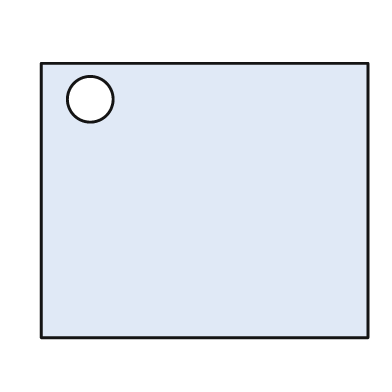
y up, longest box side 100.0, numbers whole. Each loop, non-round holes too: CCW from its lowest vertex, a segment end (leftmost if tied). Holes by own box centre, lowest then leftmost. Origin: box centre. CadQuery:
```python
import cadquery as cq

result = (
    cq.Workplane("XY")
    .moveTo(-50.0, -42.0)
    .lineTo(50.0, -42.0)
    .lineTo(50.0, 42.0)
    .lineTo(-50.0, 42.0)
    .close()
    .moveTo(-35.0, 31.0)
    .circle(7.0)
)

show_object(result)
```